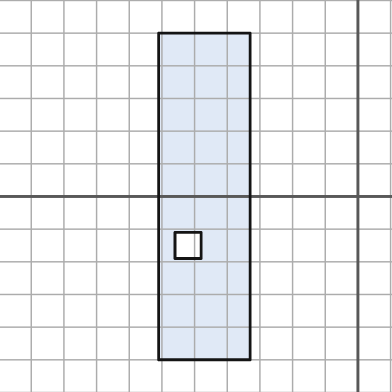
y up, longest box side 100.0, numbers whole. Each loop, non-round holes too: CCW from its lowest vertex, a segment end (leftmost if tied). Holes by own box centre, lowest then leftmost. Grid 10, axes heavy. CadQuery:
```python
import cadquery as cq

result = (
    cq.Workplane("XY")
    .moveTo(-61.0, -50.0)
    .lineTo(-33.0, -50.0)
    .lineTo(-33.0, 50.0)
    .lineTo(-61.0, 50.0)
    .close()
    .moveTo(-56.0, -19.0)
    .lineTo(-48.0, -19.0)
    .lineTo(-48.0, -11.0)
    .lineTo(-56.0, -11.0)
    .close()
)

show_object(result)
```